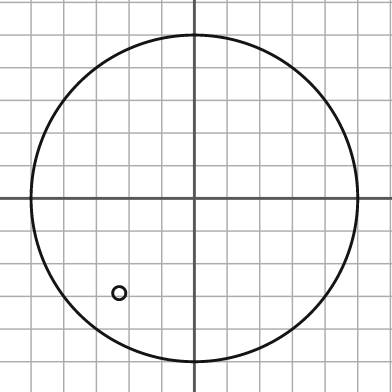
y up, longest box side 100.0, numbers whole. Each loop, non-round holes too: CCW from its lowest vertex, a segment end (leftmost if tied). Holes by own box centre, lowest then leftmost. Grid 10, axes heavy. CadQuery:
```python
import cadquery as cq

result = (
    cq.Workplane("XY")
    .moveTo(0.0, 0.0)
    .circle(50.0)
    .moveTo(-23.0, -29.0)
    .circle(2.0)
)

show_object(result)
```